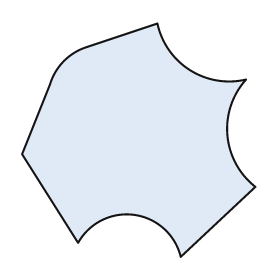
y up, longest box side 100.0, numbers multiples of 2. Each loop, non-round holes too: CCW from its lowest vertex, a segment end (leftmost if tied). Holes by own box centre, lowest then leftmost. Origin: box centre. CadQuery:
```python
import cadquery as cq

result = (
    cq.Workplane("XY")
    .moveTo(18.0, -50.0)
    .lineTo(50.0, -20.0)
    .threePointArc((38.0, 2.0), (46.0, 26.0))
    .threePointArc((22.0, 30.0), (8.0, 50.0))
    .lineTo(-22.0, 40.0)
    .threePointArc((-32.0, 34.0), (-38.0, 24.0))
    .lineTo(-50.0, -6.0)
    .lineTo(-26.0, -44.0)
    .threePointArc((-2.0, -32.0), (18.0, -50.0))
    .close()
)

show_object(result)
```